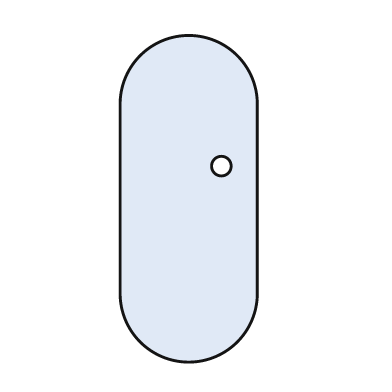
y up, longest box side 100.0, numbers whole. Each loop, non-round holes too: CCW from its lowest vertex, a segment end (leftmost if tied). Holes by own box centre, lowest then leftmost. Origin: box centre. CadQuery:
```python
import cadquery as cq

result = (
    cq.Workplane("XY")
    .moveTo(-21.0, -29.0)
    .threePointArc((0.0, -50.0), (21.0, -29.0))
    .lineTo(21.0, 29.0)
    .threePointArc((0.0, 50.0), (-21.0, 29.0))
    .close()
    .moveTo(10.0, 10.0)
    .circle(3.0)
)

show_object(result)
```